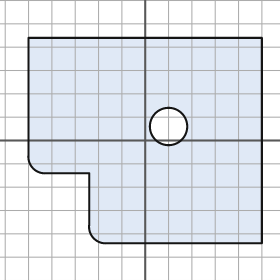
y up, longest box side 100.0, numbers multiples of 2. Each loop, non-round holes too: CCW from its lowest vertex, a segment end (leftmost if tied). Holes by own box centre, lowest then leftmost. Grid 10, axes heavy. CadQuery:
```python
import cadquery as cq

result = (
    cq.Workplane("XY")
    .moveTo(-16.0, -44.0)
    .lineTo(50.0, -44.0)
    .lineTo(50.0, 44.0)
    .lineTo(-50.0, 44.0)
    .lineTo(-50.0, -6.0)
    .threePointArc((-48.0, -12.0), (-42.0, -14.0))
    .lineTo(-24.0, -14.0)
    .lineTo(-24.0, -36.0)
    .threePointArc((-22.0, -42.0), (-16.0, -44.0))
    .close()
    .moveTo(10.0, 6.0)
    .circle(8.0)
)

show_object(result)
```